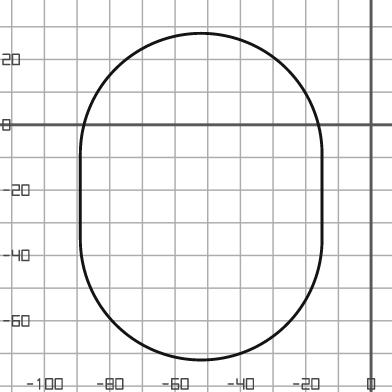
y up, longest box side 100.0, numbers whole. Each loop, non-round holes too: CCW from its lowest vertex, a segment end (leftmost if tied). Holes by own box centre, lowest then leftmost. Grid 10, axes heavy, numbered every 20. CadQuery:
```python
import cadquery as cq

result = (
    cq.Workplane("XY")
    .moveTo(-89.0, -35.0)
    .threePointArc((-52.0, -72.0), (-15.0, -35.0))
    .lineTo(-15.0, -9.0)
    .threePointArc((-52.0, 28.0), (-89.0, -9.0))
    .close()
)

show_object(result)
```